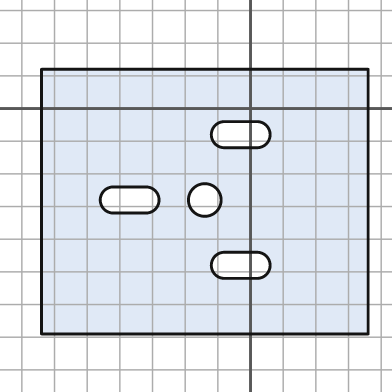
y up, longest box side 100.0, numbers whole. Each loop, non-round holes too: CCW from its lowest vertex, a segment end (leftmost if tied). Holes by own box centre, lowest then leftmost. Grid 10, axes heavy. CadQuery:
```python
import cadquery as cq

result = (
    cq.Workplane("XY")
    .moveTo(-64.0, -69.0)
    .lineTo(36.0, -69.0)
    .lineTo(36.0, 12.0)
    .lineTo(-64.0, 12.0)
    .close()
    .moveTo(-8.0, -52.0)
    .lineTo(2.0, -52.0)
    .threePointArc((6.0, -48.0), (2.0, -44.0))
    .lineTo(-8.0, -44.0)
    .threePointArc((-12.0, -48.0), (-8.0, -52.0))
    .close()
    .moveTo(-42.0, -32.0)
    .lineTo(-32.0, -32.0)
    .threePointArc((-28.0, -28.0), (-32.0, -24.0))
    .lineTo(-42.0, -24.0)
    .threePointArc((-46.0, -28.0), (-42.0, -32.0))
    .close()
    .moveTo(-14.0, -28.0)
    .circle(5.0)
    .moveTo(-8.0, -12.0)
    .lineTo(2.0, -12.0)
    .threePointArc((6.0, -8.0), (2.0, -4.0))
    .lineTo(-8.0, -4.0)
    .threePointArc((-12.0, -8.0), (-8.0, -12.0))
    .close()
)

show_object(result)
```